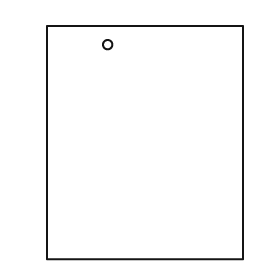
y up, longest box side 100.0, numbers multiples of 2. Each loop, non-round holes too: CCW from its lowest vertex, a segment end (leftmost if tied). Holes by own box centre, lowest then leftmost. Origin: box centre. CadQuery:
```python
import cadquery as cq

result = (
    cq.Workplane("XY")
    .moveTo(-42.0, -50.0)
    .lineTo(42.0, -50.0)
    .lineTo(42.0, 50.0)
    .lineTo(-42.0, 50.0)
    .close()
    .moveTo(-16.0, 42.0)
    .circle(2.0)
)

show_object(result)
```